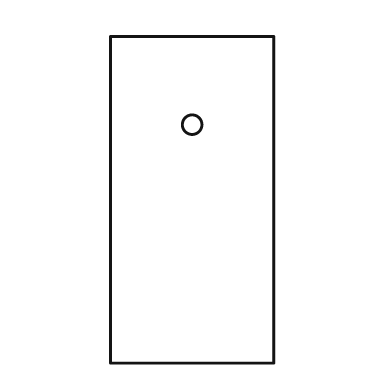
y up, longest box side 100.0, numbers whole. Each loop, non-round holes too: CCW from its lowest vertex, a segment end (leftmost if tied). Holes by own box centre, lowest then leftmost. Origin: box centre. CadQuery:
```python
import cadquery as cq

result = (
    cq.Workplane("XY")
    .moveTo(-25.0, -50.0)
    .lineTo(25.0, -50.0)
    .lineTo(25.0, 50.0)
    .lineTo(-25.0, 50.0)
    .close()
    .moveTo(0.0, 23.0)
    .circle(3.0)
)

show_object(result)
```